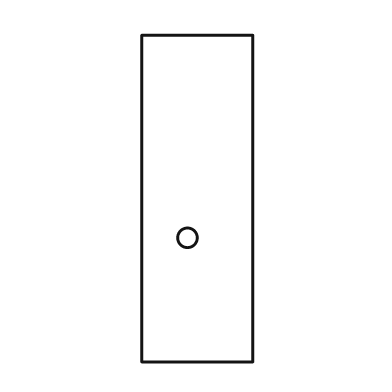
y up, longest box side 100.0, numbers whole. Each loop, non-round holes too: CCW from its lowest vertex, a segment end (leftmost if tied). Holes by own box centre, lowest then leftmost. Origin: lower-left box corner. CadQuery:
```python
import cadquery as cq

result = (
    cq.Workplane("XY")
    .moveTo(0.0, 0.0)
    .lineTo(34.0, 0.0)
    .lineTo(34.0, 100.0)
    .lineTo(0.0, 100.0)
    .close()
    .moveTo(14.0, 38.0)
    .circle(3.0)
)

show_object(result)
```